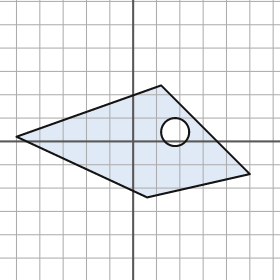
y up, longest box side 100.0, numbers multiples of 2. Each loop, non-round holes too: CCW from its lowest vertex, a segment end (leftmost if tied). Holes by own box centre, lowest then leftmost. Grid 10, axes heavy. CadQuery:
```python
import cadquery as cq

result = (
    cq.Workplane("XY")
    .moveTo(6.0, -24.0)
    .lineTo(50.0, -14.0)
    .lineTo(12.0, 24.0)
    .lineTo(-50.0, 2.0)
    .close()
    .moveTo(18.0, 4.0)
    .circle(6.0)
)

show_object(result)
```